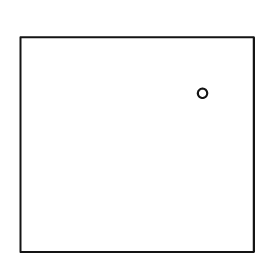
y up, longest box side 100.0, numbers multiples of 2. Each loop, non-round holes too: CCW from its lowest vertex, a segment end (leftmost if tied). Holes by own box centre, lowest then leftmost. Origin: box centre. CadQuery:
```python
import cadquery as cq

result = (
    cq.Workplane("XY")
    .moveTo(-50.0, -46.0)
    .lineTo(50.0, -46.0)
    .lineTo(50.0, 46.0)
    .lineTo(-50.0, 46.0)
    .close()
    .moveTo(28.0, 22.0)
    .circle(2.0)
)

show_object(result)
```